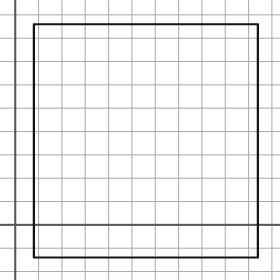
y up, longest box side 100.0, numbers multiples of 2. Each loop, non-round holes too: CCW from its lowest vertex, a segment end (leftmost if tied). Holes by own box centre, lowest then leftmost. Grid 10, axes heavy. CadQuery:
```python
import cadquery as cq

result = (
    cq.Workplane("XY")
    .moveTo(8.0, -14.0)
    .lineTo(104.0, -14.0)
    .lineTo(104.0, 86.0)
    .lineTo(8.0, 86.0)
    .close()
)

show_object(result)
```